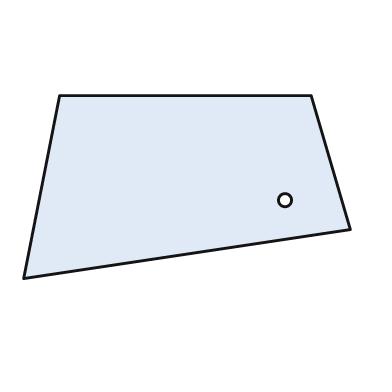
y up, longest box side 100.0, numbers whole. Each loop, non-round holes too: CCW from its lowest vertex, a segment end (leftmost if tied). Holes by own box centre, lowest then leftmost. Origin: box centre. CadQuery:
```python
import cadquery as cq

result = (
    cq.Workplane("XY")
    .moveTo(-50.0, -28.0)
    .lineTo(50.0, -13.0)
    .lineTo(38.0, 28.0)
    .lineTo(-39.0, 28.0)
    .close()
    .moveTo(30.0, -4.0)
    .circle(2.0)
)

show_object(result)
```